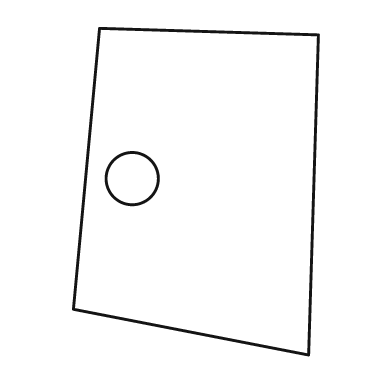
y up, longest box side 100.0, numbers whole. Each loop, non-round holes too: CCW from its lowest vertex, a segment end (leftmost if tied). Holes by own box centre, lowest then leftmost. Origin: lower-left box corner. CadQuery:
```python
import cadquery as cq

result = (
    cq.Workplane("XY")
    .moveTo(72.0, 0.0)
    .lineTo(75.0, 98.0)
    .lineTo(8.0, 100.0)
    .lineTo(0.0, 14.0)
    .close()
    .moveTo(18.0, 54.0)
    .circle(8.0)
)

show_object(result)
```